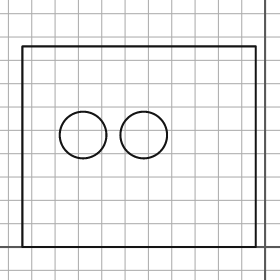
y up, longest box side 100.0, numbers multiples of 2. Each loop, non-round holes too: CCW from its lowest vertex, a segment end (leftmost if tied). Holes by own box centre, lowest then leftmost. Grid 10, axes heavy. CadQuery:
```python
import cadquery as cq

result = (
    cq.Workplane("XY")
    .moveTo(-104.0, 0.0)
    .lineTo(-4.0, 0.0)
    .lineTo(-4.0, 86.0)
    .lineTo(-104.0, 86.0)
    .close()
    .moveTo(-78.0, 48.0)
    .circle(10.0)
    .moveTo(-52.0, 48.0)
    .circle(10.0)
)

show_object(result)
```